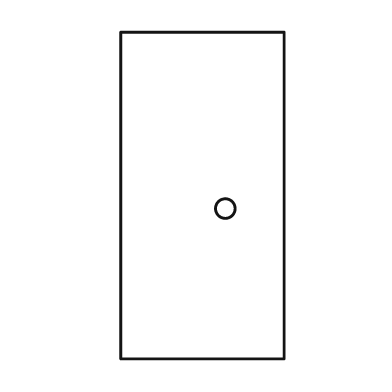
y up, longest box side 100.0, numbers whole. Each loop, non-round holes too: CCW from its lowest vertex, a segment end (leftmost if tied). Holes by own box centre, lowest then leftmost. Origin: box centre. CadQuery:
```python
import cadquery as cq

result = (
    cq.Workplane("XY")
    .moveTo(-25.0, -50.0)
    .lineTo(25.0, -50.0)
    .lineTo(25.0, 50.0)
    .lineTo(-25.0, 50.0)
    .close()
    .moveTo(7.0, -4.0)
    .circle(3.0)
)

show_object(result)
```